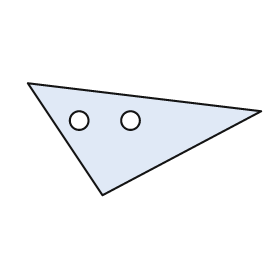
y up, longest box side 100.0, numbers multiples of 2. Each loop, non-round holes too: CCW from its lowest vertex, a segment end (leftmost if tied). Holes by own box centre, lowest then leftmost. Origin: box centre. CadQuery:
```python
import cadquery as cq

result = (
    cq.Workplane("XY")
    .moveTo(-18.0, -24.0)
    .lineTo(50.0, 12.0)
    .lineTo(-50.0, 24.0)
    .close()
    .moveTo(-28.0, 8.0)
    .circle(4.0)
    .moveTo(-6.0, 8.0)
    .circle(4.0)
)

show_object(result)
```